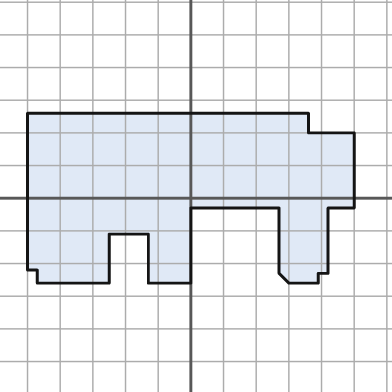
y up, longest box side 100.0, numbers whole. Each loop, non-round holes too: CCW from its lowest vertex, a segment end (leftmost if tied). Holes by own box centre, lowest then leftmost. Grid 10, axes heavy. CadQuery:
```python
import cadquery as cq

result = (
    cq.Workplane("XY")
    .moveTo(-47.0, -26.0)
    .lineTo(-25.0, -26.0)
    .lineTo(-25.0, -11.0)
    .lineTo(-13.0, -11.0)
    .lineTo(-13.0, -26.0)
    .lineTo(0.0, -26.0)
    .lineTo(0.0, -3.0)
    .lineTo(27.0, -3.0)
    .lineTo(27.0, -23.0)
    .lineTo(30.0, -26.0)
    .lineTo(39.0, -26.0)
    .lineTo(39.0, -23.0)
    .lineTo(42.0, -23.0)
    .lineTo(42.0, -3.0)
    .lineTo(50.0, -3.0)
    .lineTo(50.0, 20.0)
    .lineTo(36.0, 20.0)
    .lineTo(36.0, 26.0)
    .lineTo(-50.0, 26.0)
    .lineTo(-50.0, -22.0)
    .lineTo(-47.0, -22.0)
    .close()
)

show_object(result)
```